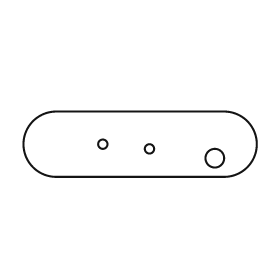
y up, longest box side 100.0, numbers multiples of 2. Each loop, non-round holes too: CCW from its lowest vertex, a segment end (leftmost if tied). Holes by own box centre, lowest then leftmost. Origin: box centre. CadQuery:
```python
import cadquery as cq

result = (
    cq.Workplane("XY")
    .moveTo(-36.0, -14.0)
    .lineTo(36.0, -14.0)
    .threePointArc((50.0, 0.0), (36.0, 14.0))
    .lineTo(-36.0, 14.0)
    .threePointArc((-50.0, 0.0), (-36.0, -14.0))
    .close()
    .moveTo(32.0, -6.0)
    .circle(4.0)
    .moveTo(4.0, -2.0)
    .circle(2.0)
    .moveTo(-16.0, 0.0)
    .circle(2.0)
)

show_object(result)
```